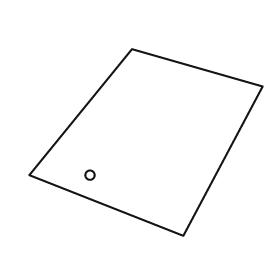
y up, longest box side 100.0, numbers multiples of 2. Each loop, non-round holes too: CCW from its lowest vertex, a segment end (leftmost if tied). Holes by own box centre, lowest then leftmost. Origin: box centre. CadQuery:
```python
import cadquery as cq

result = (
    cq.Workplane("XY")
    .moveTo(16.0, -40.0)
    .lineTo(50.0, 24.0)
    .lineTo(-6.0, 40.0)
    .lineTo(-50.0, -14.0)
    .close()
    .moveTo(-24.0, -14.0)
    .circle(2.0)
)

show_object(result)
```